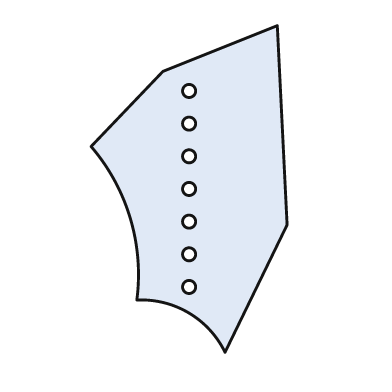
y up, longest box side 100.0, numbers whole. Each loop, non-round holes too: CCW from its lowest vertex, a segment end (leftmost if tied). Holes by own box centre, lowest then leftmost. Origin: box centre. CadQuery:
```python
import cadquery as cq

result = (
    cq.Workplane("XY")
    .moveTo(11.0, -50.0)
    .lineTo(30.0, -11.0)
    .lineTo(27.0, 50.0)
    .lineTo(-8.0, 36.0)
    .lineTo(-30.0, 13.0)
    .threePointArc((-18.0, -9.0), (-16.0, -34.0))
    .threePointArc((0.0, -38.0), (11.0, -50.0))
    .close()
    .moveTo(0.0, -30.0)
    .circle(2.0)
    .moveTo(0.0, -20.0)
    .circle(2.0)
    .moveTo(0.0, -10.0)
    .circle(2.0)
    .moveTo(0.0, 0.0)
    .circle(2.0)
    .moveTo(0.0, 10.0)
    .circle(2.0)
    .moveTo(0.0, 20.0)
    .circle(2.0)
    .moveTo(0.0, 30.0)
    .circle(2.0)
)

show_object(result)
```